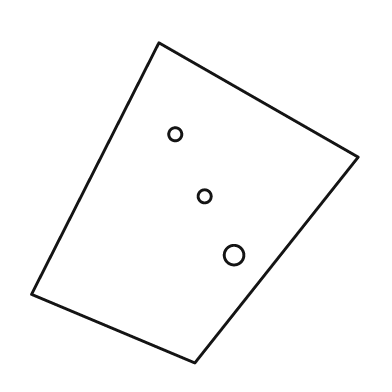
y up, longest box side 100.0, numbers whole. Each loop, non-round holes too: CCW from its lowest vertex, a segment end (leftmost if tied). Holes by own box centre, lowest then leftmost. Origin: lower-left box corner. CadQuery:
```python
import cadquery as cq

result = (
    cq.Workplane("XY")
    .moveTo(50.0, 0.0)
    .lineTo(100.0, 63.0)
    .lineTo(39.0, 98.0)
    .lineTo(0.0, 21.0)
    .close()
    .moveTo(62.0, 33.0)
    .circle(3.0)
    .moveTo(53.0, 51.0)
    .circle(2.0)
    .moveTo(44.0, 70.0)
    .circle(2.0)
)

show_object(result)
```